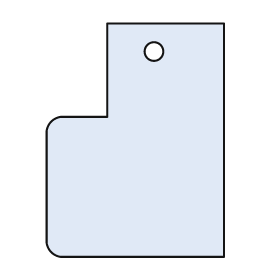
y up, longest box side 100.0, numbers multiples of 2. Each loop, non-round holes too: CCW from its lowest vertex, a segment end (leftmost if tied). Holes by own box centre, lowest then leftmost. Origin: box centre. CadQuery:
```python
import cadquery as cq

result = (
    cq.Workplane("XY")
    .moveTo(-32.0, -50.0)
    .lineTo(38.0, -50.0)
    .lineTo(38.0, 50.0)
    .lineTo(-12.0, 50.0)
    .lineTo(-12.0, 10.0)
    .lineTo(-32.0, 10.0)
    .threePointArc((-36.0, 8.0), (-38.0, 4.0))
    .lineTo(-38.0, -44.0)
    .threePointArc((-36.0, -48.0), (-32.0, -50.0))
    .close()
    .moveTo(8.0, 38.0)
    .circle(4.0)
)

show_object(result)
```